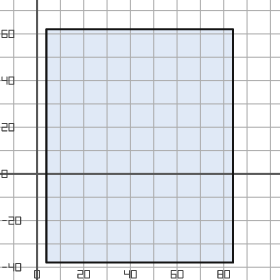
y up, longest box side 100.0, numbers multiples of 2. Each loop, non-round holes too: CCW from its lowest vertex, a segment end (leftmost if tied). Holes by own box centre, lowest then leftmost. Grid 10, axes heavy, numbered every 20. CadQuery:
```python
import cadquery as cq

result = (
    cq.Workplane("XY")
    .moveTo(4.0, -38.0)
    .lineTo(84.0, -38.0)
    .lineTo(84.0, 62.0)
    .lineTo(4.0, 62.0)
    .close()
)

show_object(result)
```